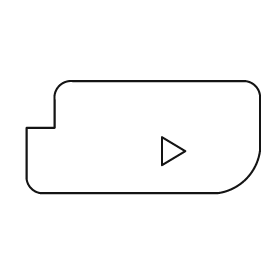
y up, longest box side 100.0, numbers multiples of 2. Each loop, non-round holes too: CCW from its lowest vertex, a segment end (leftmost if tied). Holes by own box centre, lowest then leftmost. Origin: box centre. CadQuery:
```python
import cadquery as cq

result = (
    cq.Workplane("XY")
    .moveTo(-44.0, -24.0)
    .lineTo(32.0, -24.0)
    .threePointArc((44.0, -18.0), (50.0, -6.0))
    .lineTo(50.0, 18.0)
    .threePointArc((48.0, 22.0), (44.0, 24.0))
    .lineTo(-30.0, 24.0)
    .threePointArc((-36.0, 22.0), (-38.0, 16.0))
    .lineTo(-38.0, 4.0)
    .lineTo(-50.0, 4.0)
    .lineTo(-50.0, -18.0)
    .threePointArc((-48.0, -22.0), (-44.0, -24.0))
    .close()
    .moveTo(8.0, -12.0)
    .lineTo(18.0, -6.0)
    .lineTo(8.0, 0.0)
    .close()
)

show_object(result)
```